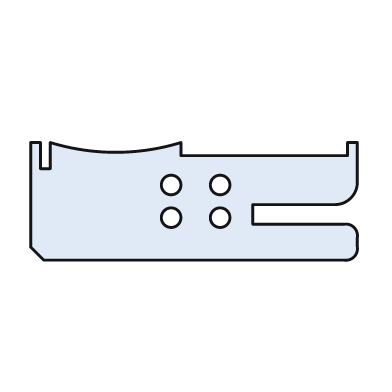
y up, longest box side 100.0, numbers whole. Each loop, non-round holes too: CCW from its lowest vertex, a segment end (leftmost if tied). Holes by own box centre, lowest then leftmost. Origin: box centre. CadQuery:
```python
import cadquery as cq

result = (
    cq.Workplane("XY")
    .moveTo(-46.0, -18.0)
    .lineTo(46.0, -18.0)
    .threePointArc((49.0, -17.0), (50.0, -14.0))
    .lineTo(50.0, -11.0)
    .threePointArc((49.0, -8.0), (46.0, -7.0))
    .lineTo(18.0, -7.0)
    .lineTo(18.0, -1.0)
    .lineTo(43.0, -1.0)
    .threePointArc((48.0, 1.0), (50.0, 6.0))
    .lineTo(50.0, 18.0)
    .lineTo(47.0, 18.0)
    .lineTo(47.0, 14.0)
    .lineTo(-4.0, 14.0)
    .lineTo(-4.0, 18.0)
    .threePointArc((-24.0, 15.0), (-44.0, 18.0))
    .lineTo(-44.0, 10.0)
    .lineTo(-47.0, 10.0)
    .lineTo(-47.0, 18.0)
    .lineTo(-50.0, 18.0)
    .lineTo(-50.0, -14.0)
    .close()
    .moveTo(-7.0, -5.0)
    .circle(3.0)
    .moveTo(8.0, -5.0)
    .circle(3.0)
    .moveTo(-7.0, 5.0)
    .circle(3.0)
    .moveTo(8.0, 5.0)
    .circle(3.0)
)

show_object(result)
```